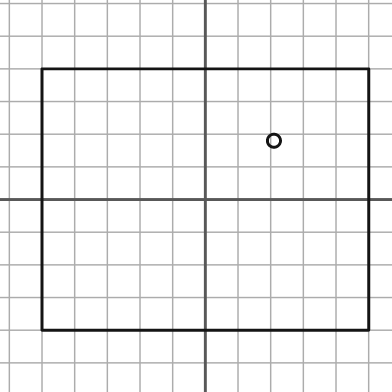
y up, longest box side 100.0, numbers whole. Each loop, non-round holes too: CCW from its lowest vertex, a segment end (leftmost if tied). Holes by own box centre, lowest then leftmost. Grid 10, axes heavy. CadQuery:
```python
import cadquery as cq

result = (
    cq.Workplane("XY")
    .moveTo(-50.0, -40.0)
    .lineTo(50.0, -40.0)
    .lineTo(50.0, 40.0)
    .lineTo(-50.0, 40.0)
    .close()
    .moveTo(21.0, 18.0)
    .circle(2.0)
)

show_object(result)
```